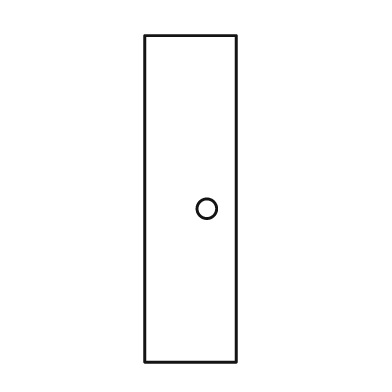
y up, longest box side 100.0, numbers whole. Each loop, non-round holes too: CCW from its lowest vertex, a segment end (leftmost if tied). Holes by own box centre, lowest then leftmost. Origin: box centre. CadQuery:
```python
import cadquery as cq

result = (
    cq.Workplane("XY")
    .moveTo(-14.0, -50.0)
    .lineTo(14.0, -50.0)
    .lineTo(14.0, 50.0)
    .lineTo(-14.0, 50.0)
    .close()
    .moveTo(5.0, -3.0)
    .circle(3.0)
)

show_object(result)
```